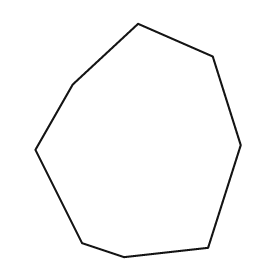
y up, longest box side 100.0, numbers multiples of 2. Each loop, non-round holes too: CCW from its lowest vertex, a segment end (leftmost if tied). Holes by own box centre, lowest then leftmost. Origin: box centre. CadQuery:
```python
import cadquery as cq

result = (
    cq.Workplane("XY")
    .moveTo(-6.0, -50.0)
    .lineTo(30.0, -46.0)
    .lineTo(44.0, -2.0)
    .lineTo(32.0, 36.0)
    .lineTo(0.0, 50.0)
    .lineTo(-28.0, 24.0)
    .lineTo(-44.0, -4.0)
    .lineTo(-24.0, -44.0)
    .close()
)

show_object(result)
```